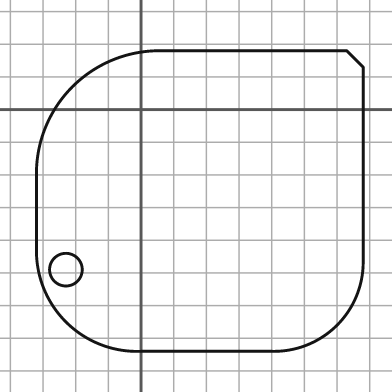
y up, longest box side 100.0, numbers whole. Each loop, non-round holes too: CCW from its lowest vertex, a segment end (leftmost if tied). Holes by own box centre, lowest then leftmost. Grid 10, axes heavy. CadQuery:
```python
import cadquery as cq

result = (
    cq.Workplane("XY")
    .moveTo(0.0, -74.0)
    .lineTo(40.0, -74.0)
    .threePointArc((60.0, -66.0), (68.0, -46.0))
    .lineTo(68.0, 13.0)
    .lineTo(63.0, 18.0)
    .lineTo(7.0, 18.0)
    .threePointArc((-21.0, 7.0), (-32.0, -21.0))
    .lineTo(-32.0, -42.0)
    .threePointArc((-23.0, -65.0), (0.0, -74.0))
    .close()
    .moveTo(-23.0, -49.0)
    .circle(5.0)
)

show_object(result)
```